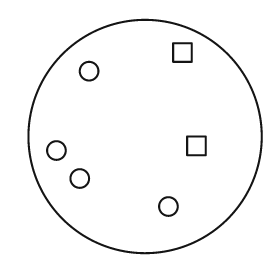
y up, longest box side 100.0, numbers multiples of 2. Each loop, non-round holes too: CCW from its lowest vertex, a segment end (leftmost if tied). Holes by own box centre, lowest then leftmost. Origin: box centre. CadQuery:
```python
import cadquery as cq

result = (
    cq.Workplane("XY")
    .moveTo(0.0, 0.0)
    .circle(50.0)
    .moveTo(10.0, -30.0)
    .circle(4.0)
    .moveTo(-28.0, -18.0)
    .circle(4.0)
    .moveTo(-38.0, -6.0)
    .circle(4.0)
    .moveTo(18.0, -8.0)
    .lineTo(26.0, -8.0)
    .lineTo(26.0, 0.0)
    .lineTo(18.0, 0.0)
    .close()
    .moveTo(-24.0, 28.0)
    .circle(4.0)
    .moveTo(12.0, 32.0)
    .lineTo(20.0, 32.0)
    .lineTo(20.0, 40.0)
    .lineTo(12.0, 40.0)
    .close()
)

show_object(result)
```